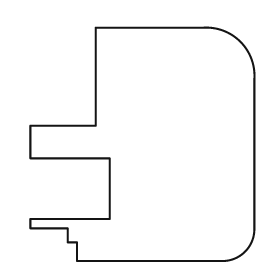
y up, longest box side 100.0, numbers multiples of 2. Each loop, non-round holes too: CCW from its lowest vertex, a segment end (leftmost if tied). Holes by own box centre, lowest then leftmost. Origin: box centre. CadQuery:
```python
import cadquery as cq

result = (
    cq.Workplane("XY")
    .moveTo(-28.0, -50.0)
    .lineTo(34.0, -50.0)
    .threePointArc((44.0, -46.0), (48.0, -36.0))
    .lineTo(48.0, 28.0)
    .threePointArc((42.0, 44.0), (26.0, 50.0))
    .lineTo(-20.0, 50.0)
    .lineTo(-20.0, 8.0)
    .lineTo(-48.0, 8.0)
    .lineTo(-48.0, -6.0)
    .lineTo(-14.0, -6.0)
    .lineTo(-14.0, -32.0)
    .lineTo(-48.0, -32.0)
    .lineTo(-48.0, -36.0)
    .lineTo(-32.0, -36.0)
    .lineTo(-32.0, -42.0)
    .lineTo(-28.0, -42.0)
    .close()
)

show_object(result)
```